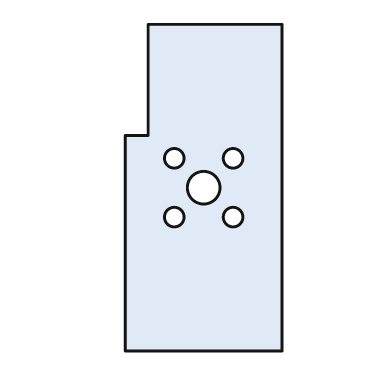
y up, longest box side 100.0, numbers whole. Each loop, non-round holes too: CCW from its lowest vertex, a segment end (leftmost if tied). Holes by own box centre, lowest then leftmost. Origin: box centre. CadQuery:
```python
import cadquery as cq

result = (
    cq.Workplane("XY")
    .moveTo(-24.0, -50.0)
    .lineTo(24.0, -50.0)
    .lineTo(24.0, 50.0)
    .lineTo(-17.0, 50.0)
    .lineTo(-17.0, 16.0)
    .lineTo(-24.0, 16.0)
    .close()
    .moveTo(-9.0, -9.0)
    .circle(3.0)
    .moveTo(9.0, -9.0)
    .circle(3.0)
    .moveTo(0.0, 0.0)
    .circle(5.0)
    .moveTo(-9.0, 9.0)
    .circle(3.0)
    .moveTo(9.0, 9.0)
    .circle(3.0)
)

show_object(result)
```